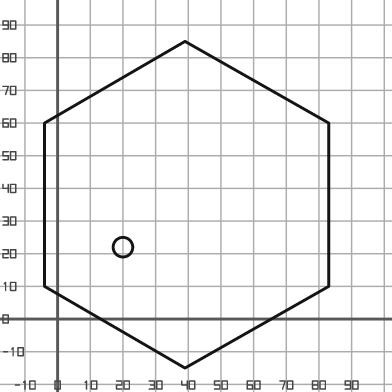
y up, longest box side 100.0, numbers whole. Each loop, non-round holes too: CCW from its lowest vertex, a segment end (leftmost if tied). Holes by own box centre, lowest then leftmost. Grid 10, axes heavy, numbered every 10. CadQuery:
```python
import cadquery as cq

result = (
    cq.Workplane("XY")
    .moveTo(39.0, -15.0)
    .lineTo(83.0, 10.0)
    .lineTo(83.0, 60.0)
    .lineTo(39.0, 85.0)
    .lineTo(-4.0, 60.0)
    .lineTo(-4.0, 10.0)
    .close()
    .moveTo(20.0, 22.0)
    .circle(3.0)
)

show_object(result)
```